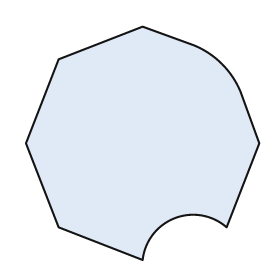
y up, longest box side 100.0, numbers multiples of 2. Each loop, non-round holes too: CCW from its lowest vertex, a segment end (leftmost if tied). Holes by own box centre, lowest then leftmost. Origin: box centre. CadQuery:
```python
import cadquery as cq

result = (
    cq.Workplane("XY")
    .moveTo(0.0, -50.0)
    .threePointArc((14.0, -32.0), (36.0, -36.0))
    .lineTo(50.0, 0.0)
    .lineTo(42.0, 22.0)
    .threePointArc((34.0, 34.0), (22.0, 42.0))
    .lineTo(0.0, 50.0)
    .lineTo(-36.0, 36.0)
    .lineTo(-50.0, 0.0)
    .lineTo(-36.0, -36.0)
    .close()
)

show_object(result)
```